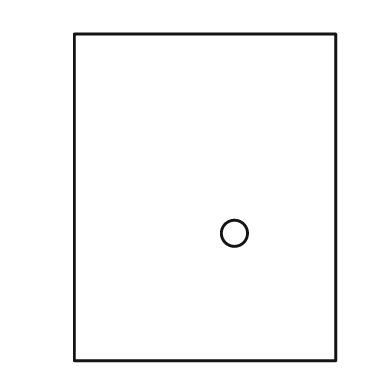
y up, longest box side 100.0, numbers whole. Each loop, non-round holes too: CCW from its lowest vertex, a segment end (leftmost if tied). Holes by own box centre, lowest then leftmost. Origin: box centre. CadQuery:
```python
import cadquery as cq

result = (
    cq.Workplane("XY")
    .moveTo(-40.0, -50.0)
    .lineTo(40.0, -50.0)
    .lineTo(40.0, 50.0)
    .lineTo(-40.0, 50.0)
    .close()
    .moveTo(9.0, -11.0)
    .circle(4.0)
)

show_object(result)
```